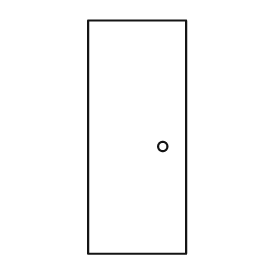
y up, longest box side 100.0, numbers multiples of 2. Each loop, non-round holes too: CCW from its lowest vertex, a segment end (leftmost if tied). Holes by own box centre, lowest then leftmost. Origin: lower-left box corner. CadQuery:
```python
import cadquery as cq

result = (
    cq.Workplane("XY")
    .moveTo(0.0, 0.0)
    .lineTo(42.0, 0.0)
    .lineTo(42.0, 100.0)
    .lineTo(0.0, 100.0)
    .close()
    .moveTo(32.0, 46.0)
    .circle(2.0)
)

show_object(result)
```